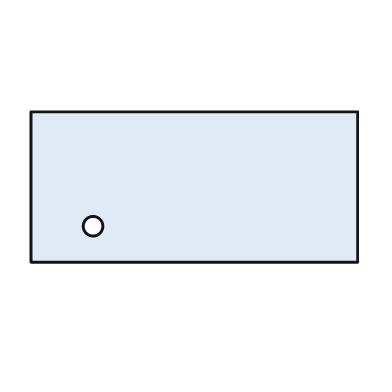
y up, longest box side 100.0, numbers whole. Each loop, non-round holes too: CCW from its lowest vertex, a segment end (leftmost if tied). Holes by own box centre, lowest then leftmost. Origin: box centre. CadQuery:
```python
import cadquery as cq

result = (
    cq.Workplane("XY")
    .moveTo(-50.0, -23.0)
    .lineTo(50.0, -23.0)
    .lineTo(50.0, 23.0)
    .lineTo(-50.0, 23.0)
    .close()
    .moveTo(-31.0, -12.0)
    .circle(3.0)
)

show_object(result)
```